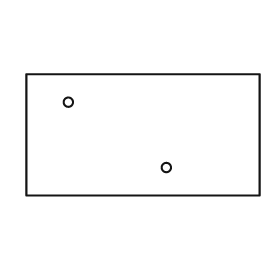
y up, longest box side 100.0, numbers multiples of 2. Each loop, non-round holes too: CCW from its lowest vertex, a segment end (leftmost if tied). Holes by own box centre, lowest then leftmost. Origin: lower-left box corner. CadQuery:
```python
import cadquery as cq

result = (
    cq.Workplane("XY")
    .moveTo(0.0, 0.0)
    .lineTo(100.0, 0.0)
    .lineTo(100.0, 52.0)
    .lineTo(0.0, 52.0)
    .close()
    .moveTo(60.0, 12.0)
    .circle(2.0)
    .moveTo(18.0, 40.0)
    .circle(2.0)
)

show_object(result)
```